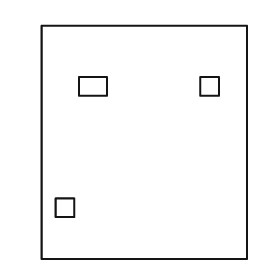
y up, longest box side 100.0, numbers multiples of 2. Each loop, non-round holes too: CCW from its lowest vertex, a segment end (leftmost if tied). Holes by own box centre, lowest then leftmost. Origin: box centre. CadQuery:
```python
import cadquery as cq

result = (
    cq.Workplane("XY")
    .moveTo(-44.0, -50.0)
    .lineTo(44.0, -50.0)
    .lineTo(44.0, 50.0)
    .lineTo(-44.0, 50.0)
    .close()
    .moveTo(-38.0, -32.0)
    .lineTo(-30.0, -32.0)
    .lineTo(-30.0, -24.0)
    .lineTo(-38.0, -24.0)
    .close()
    .moveTo(-28.0, 20.0)
    .lineTo(-16.0, 20.0)
    .lineTo(-16.0, 28.0)
    .lineTo(-28.0, 28.0)
    .close()
    .moveTo(24.0, 20.0)
    .lineTo(32.0, 20.0)
    .lineTo(32.0, 28.0)
    .lineTo(24.0, 28.0)
    .close()
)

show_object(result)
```